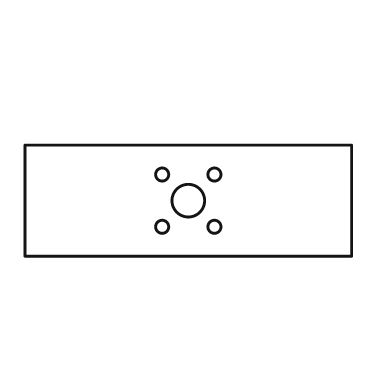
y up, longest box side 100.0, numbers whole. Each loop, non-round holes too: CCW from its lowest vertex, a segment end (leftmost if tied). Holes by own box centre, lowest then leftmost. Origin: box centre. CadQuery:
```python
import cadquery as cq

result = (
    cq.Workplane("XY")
    .moveTo(-50.0, -17.0)
    .lineTo(50.0, -17.0)
    .lineTo(50.0, 17.0)
    .lineTo(-50.0, 17.0)
    .close()
    .moveTo(-8.0, -8.0)
    .circle(2.0)
    .moveTo(8.0, -8.0)
    .circle(2.0)
    .moveTo(0.0, 0.0)
    .circle(5.0)
    .moveTo(-8.0, 8.0)
    .circle(2.0)
    .moveTo(8.0, 8.0)
    .circle(2.0)
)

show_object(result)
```